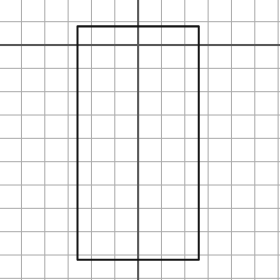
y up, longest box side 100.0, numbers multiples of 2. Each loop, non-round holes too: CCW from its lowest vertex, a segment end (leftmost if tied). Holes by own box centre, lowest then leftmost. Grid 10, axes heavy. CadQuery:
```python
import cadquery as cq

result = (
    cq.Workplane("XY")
    .moveTo(-26.0, -92.0)
    .lineTo(26.0, -92.0)
    .lineTo(26.0, 8.0)
    .lineTo(-26.0, 8.0)
    .close()
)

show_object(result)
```